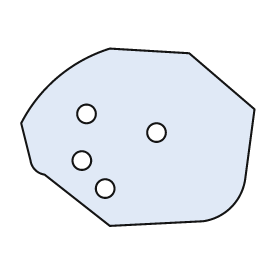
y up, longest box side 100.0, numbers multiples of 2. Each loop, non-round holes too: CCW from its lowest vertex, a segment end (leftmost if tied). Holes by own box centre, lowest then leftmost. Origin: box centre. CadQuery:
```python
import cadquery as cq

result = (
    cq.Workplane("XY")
    .moveTo(-12.0, -38.0)
    .lineTo(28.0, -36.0)
    .threePointArc((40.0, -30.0), (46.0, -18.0))
    .lineTo(50.0, 12.0)
    .lineTo(22.0, 36.0)
    .lineTo(-12.0, 38.0)
    .threePointArc((-34.0, 26.0), (-50.0, 6.0))
    .lineTo(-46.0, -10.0)
    .threePointArc((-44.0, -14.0), (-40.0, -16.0))
    .close()
    .moveTo(-14.0, -22.0)
    .circle(4.0)
    .moveTo(-24.0, -10.0)
    .circle(4.0)
    .moveTo(8.0, 2.0)
    .circle(4.0)
    .moveTo(-22.0, 10.0)
    .circle(4.0)
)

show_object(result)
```